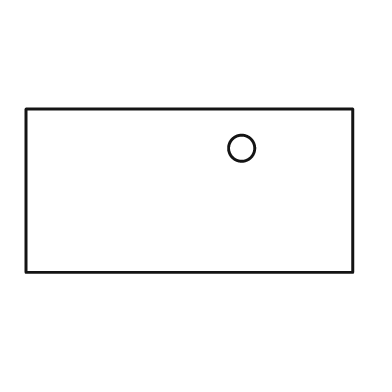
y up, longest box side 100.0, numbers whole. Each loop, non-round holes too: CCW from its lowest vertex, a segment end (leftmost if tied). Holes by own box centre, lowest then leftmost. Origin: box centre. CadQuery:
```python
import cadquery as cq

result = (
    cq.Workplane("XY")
    .moveTo(-50.0, -25.0)
    .lineTo(50.0, -25.0)
    .lineTo(50.0, 25.0)
    .lineTo(-50.0, 25.0)
    .close()
    .moveTo(16.0, 13.0)
    .circle(4.0)
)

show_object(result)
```